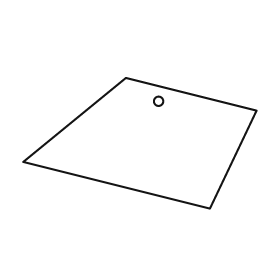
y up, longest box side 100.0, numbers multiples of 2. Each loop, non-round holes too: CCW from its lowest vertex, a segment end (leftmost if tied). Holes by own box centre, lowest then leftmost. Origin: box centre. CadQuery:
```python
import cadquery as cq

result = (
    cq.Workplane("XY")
    .moveTo(30.0, -28.0)
    .lineTo(50.0, 14.0)
    .lineTo(-6.0, 28.0)
    .lineTo(-50.0, -8.0)
    .close()
    .moveTo(8.0, 18.0)
    .circle(2.0)
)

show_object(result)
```